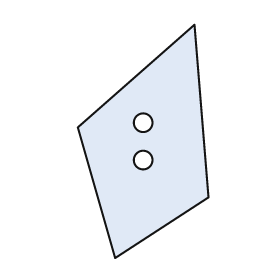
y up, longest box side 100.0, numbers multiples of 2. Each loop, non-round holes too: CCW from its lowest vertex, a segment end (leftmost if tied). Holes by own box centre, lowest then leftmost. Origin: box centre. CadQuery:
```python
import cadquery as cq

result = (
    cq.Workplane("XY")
    .moveTo(-12.0, -50.0)
    .lineTo(28.0, -24.0)
    .lineTo(22.0, 50.0)
    .lineTo(-28.0, 6.0)
    .close()
    .moveTo(0.0, -8.0)
    .circle(4.0)
    .moveTo(0.0, 8.0)
    .circle(4.0)
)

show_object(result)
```